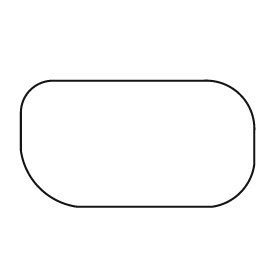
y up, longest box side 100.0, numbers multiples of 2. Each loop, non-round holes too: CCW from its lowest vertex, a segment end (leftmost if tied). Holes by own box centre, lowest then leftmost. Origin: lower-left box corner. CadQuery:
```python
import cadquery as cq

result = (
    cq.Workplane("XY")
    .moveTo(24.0, 0.0)
    .lineTo(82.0, 0.0)
    .threePointArc((94.0, 6.0), (100.0, 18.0))
    .lineTo(100.0, 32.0)
    .threePointArc((94.0, 48.0), (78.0, 54.0))
    .lineTo(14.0, 54.0)
    .threePointArc((4.0, 50.0), (0.0, 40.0))
    .lineTo(0.0, 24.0)
    .threePointArc((8.0, 8.0), (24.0, 0.0))
    .close()
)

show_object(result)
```